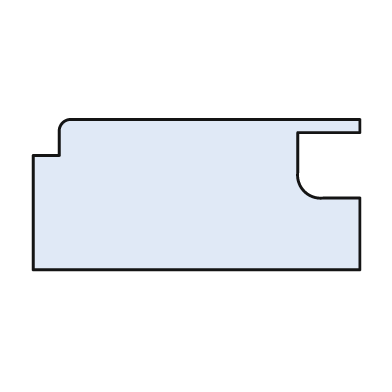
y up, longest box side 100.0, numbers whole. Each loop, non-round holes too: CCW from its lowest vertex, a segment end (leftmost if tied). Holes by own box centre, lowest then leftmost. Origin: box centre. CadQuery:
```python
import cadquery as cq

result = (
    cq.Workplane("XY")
    .moveTo(-50.0, -23.0)
    .lineTo(50.0, -23.0)
    .lineTo(50.0, -1.0)
    .lineTo(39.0, -1.0)
    .threePointArc((33.0, 1.0), (31.0, 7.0))
    .lineTo(31.0, 19.0)
    .lineTo(50.0, 19.0)
    .lineTo(50.0, 23.0)
    .lineTo(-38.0, 23.0)
    .threePointArc((-41.0, 22.0), (-42.0, 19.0))
    .lineTo(-42.0, 12.0)
    .lineTo(-50.0, 12.0)
    .close()
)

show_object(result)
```